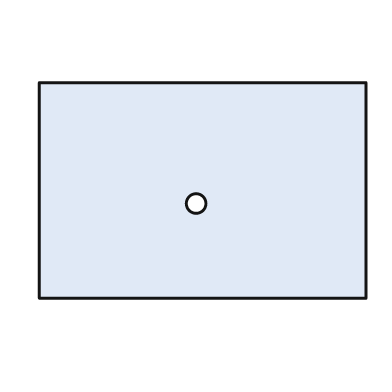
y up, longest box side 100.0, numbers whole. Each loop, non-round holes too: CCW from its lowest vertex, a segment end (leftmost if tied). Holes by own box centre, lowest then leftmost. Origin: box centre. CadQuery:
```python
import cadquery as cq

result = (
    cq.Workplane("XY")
    .moveTo(-50.0, -33.0)
    .lineTo(50.0, -33.0)
    .lineTo(50.0, 33.0)
    .lineTo(-50.0, 33.0)
    .close()
    .moveTo(-2.0, -4.0)
    .circle(3.0)
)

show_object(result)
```